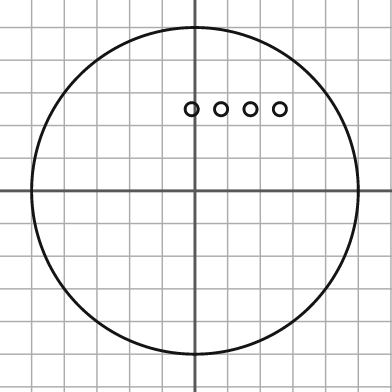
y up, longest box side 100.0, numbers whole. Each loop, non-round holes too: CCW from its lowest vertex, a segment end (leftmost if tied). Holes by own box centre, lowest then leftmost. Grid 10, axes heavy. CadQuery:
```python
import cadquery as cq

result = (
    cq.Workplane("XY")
    .moveTo(0.0, 0.0)
    .circle(50.0)
    .moveTo(-1.0, 25.0)
    .circle(2.0)
    .moveTo(8.0, 25.0)
    .circle(2.0)
    .moveTo(17.0, 25.0)
    .circle(2.0)
    .moveTo(26.0, 25.0)
    .circle(2.0)
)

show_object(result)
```